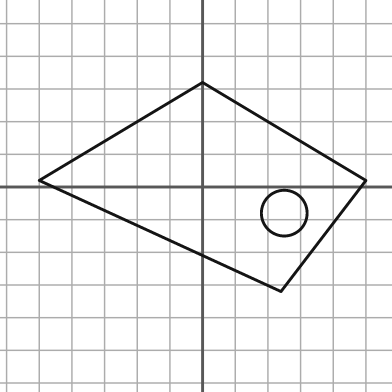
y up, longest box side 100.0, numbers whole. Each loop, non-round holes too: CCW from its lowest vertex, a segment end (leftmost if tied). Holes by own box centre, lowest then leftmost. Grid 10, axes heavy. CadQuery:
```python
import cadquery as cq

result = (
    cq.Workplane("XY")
    .moveTo(24.0, -32.0)
    .lineTo(50.0, 2.0)
    .lineTo(0.0, 32.0)
    .lineTo(-50.0, 2.0)
    .close()
    .moveTo(25.0, -8.0)
    .circle(7.0)
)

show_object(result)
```